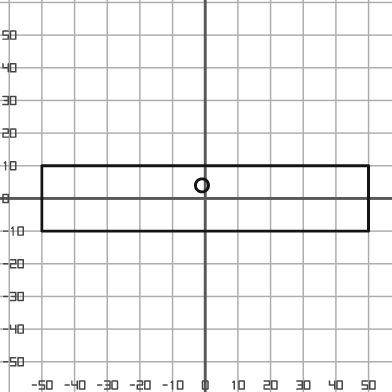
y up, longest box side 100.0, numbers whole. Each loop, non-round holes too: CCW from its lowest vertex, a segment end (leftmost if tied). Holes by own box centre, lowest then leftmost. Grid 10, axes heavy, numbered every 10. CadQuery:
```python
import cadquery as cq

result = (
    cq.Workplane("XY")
    .moveTo(-50.0, -10.0)
    .lineTo(50.0, -10.0)
    .lineTo(50.0, 10.0)
    .lineTo(-50.0, 10.0)
    .close()
    .moveTo(-1.0, 4.0)
    .circle(2.0)
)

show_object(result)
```